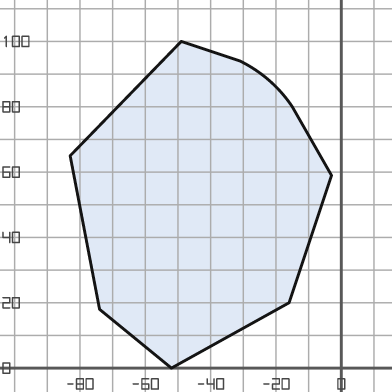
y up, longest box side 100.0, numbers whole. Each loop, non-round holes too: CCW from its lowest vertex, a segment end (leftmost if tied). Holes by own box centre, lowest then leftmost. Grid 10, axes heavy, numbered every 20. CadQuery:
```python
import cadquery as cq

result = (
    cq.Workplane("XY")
    .moveTo(-52.0, 0.0)
    .lineTo(-16.0, 20.0)
    .lineTo(-3.0, 59.0)
    .lineTo(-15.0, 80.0)
    .threePointArc((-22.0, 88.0), (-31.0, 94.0))
    .lineTo(-49.0, 100.0)
    .lineTo(-83.0, 65.0)
    .lineTo(-74.0, 18.0)
    .close()
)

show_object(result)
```